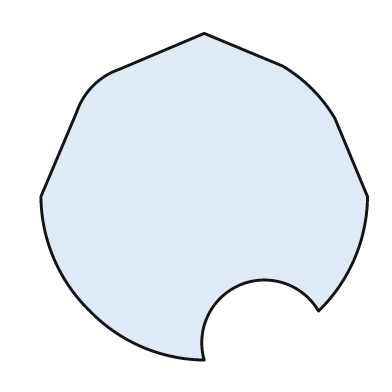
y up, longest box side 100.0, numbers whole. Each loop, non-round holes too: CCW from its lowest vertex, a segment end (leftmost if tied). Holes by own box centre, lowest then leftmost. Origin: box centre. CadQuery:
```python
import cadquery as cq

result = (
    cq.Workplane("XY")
    .moveTo(0.0, -50.0)
    .threePointArc((11.0, -27.0), (35.0, -35.0))
    .threePointArc((46.0, -19.0), (50.0, 0.0))
    .lineTo(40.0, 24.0)
    .threePointArc((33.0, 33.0), (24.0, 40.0))
    .lineTo(0.0, 50.0)
    .lineTo(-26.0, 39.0)
    .threePointArc((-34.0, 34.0), (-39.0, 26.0))
    .lineTo(-50.0, 0.0)
    .threePointArc((-46.0, -19.0), (-35.0, -35.0))
    .threePointArc((-19.0, -46.0), (0.0, -50.0))
    .close()
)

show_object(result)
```